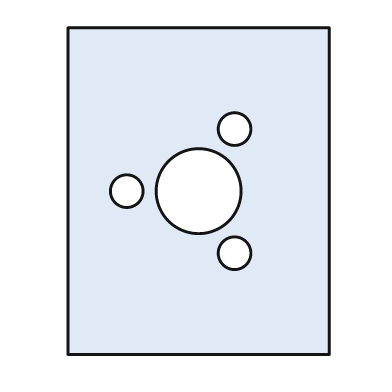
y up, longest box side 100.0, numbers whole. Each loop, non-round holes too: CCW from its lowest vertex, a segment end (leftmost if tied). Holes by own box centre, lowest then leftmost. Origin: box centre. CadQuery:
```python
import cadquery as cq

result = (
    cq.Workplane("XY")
    .moveTo(-40.0, -50.0)
    .lineTo(40.0, -50.0)
    .lineTo(40.0, 50.0)
    .lineTo(-40.0, 50.0)
    .close()
    .moveTo(11.0, -19.0)
    .circle(5.0)
    .moveTo(-22.0, 0.0)
    .circle(5.0)
    .moveTo(0.0, 0.0)
    .circle(13.0)
    .moveTo(11.0, 19.0)
    .circle(5.0)
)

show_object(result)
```